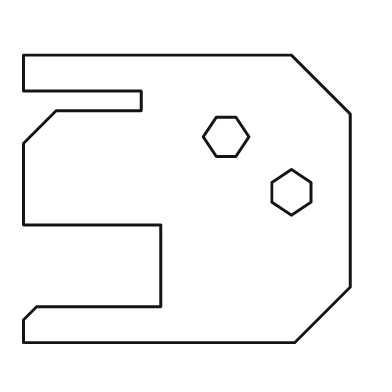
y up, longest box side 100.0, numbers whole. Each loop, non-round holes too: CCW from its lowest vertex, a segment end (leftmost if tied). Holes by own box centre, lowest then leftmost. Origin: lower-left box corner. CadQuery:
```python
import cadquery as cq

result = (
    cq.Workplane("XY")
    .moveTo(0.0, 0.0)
    .lineTo(83.0, 0.0)
    .lineTo(100.0, 17.0)
    .lineTo(100.0, 70.0)
    .lineTo(82.0, 88.0)
    .lineTo(0.0, 88.0)
    .lineTo(0.0, 77.0)
    .lineTo(36.0, 77.0)
    .lineTo(36.0, 71.0)
    .lineTo(10.0, 71.0)
    .lineTo(0.0, 61.0)
    .lineTo(0.0, 36.0)
    .lineTo(42.0, 36.0)
    .lineTo(42.0, 11.0)
    .lineTo(4.0, 11.0)
    .lineTo(0.0, 7.0)
    .close()
    .moveTo(82.0, 39.0)
    .lineTo(88.0, 43.0)
    .lineTo(88.0, 49.0)
    .lineTo(82.0, 53.0)
    .lineTo(76.0, 49.0)
    .lineTo(76.0, 43.0)
    .close()
    .moveTo(59.0, 57.0)
    .lineTo(65.0, 57.0)
    .lineTo(69.0, 63.0)
    .lineTo(65.0, 69.0)
    .lineTo(59.0, 69.0)
    .lineTo(55.0, 63.0)
    .close()
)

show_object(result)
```